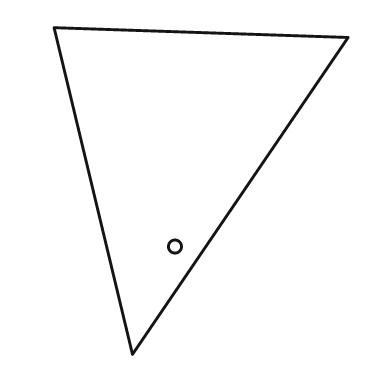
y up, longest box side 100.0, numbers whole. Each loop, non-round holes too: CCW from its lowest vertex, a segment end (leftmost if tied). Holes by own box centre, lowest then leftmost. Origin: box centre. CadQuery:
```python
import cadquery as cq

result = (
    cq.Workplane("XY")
    .moveTo(-21.0, -50.0)
    .lineTo(45.0, 47.0)
    .lineTo(-45.0, 50.0)
    .close()
    .moveTo(-8.0, -17.0)
    .circle(2.0)
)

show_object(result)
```